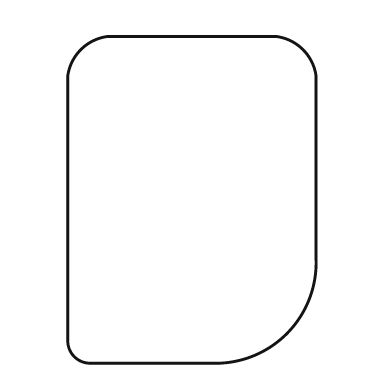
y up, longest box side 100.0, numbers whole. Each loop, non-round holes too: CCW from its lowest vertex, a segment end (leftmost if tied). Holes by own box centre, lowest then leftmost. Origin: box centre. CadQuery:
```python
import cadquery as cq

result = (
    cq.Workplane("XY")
    .moveTo(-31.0, -50.0)
    .lineTo(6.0, -50.0)
    .threePointArc((29.0, -41.0), (38.0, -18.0))
    .lineTo(38.0, 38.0)
    .threePointArc((34.0, 46.0), (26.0, 50.0))
    .lineTo(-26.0, 50.0)
    .threePointArc((-34.0, 46.0), (-38.0, 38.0))
    .lineTo(-38.0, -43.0)
    .threePointArc((-36.0, -48.0), (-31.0, -50.0))
    .close()
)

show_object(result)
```